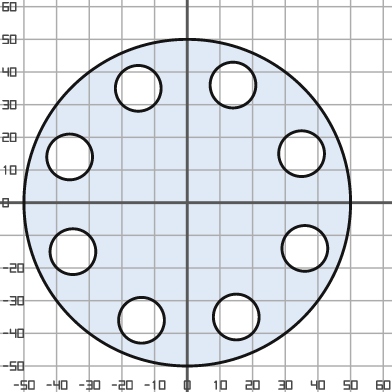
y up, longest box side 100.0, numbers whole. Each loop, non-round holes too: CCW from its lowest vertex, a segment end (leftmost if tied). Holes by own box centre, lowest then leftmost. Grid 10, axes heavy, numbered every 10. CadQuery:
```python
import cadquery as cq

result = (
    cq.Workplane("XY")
    .moveTo(0.0, 0.0)
    .circle(50.0)
    .moveTo(-14.0, -36.0)
    .circle(7.0)
    .moveTo(15.0, -35.0)
    .circle(7.0)
    .moveTo(-35.0, -15.0)
    .circle(7.0)
    .moveTo(36.0, -14.0)
    .circle(7.0)
    .moveTo(-36.0, 14.0)
    .circle(7.0)
    .moveTo(35.0, 15.0)
    .circle(7.0)
    .moveTo(-15.0, 35.0)
    .circle(7.0)
    .moveTo(14.0, 36.0)
    .circle(7.0)
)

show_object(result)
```